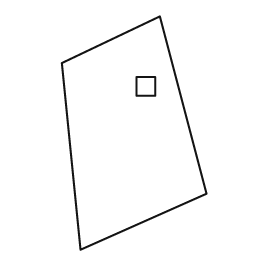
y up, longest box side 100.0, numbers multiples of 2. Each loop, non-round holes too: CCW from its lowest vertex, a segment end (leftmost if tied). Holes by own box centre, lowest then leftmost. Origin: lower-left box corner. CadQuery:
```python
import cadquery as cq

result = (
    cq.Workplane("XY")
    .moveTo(8.0, 0.0)
    .lineTo(62.0, 24.0)
    .lineTo(42.0, 100.0)
    .lineTo(0.0, 80.0)
    .close()
    .moveTo(32.0, 66.0)
    .lineTo(40.0, 66.0)
    .lineTo(40.0, 74.0)
    .lineTo(32.0, 74.0)
    .close()
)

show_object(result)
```